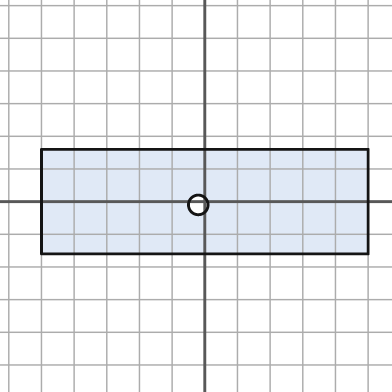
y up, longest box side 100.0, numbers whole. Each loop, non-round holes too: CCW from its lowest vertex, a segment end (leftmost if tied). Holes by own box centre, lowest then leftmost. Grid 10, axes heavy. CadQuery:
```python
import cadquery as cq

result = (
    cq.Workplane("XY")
    .moveTo(-50.0, -16.0)
    .lineTo(50.0, -16.0)
    .lineTo(50.0, 16.0)
    .lineTo(-50.0, 16.0)
    .close()
    .moveTo(-2.0, -1.0)
    .circle(3.0)
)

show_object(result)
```